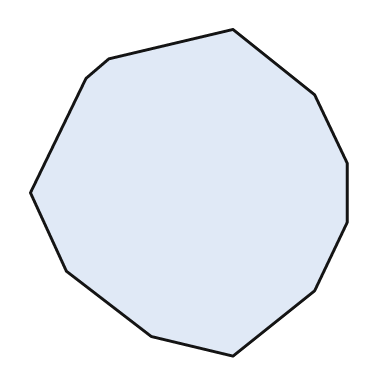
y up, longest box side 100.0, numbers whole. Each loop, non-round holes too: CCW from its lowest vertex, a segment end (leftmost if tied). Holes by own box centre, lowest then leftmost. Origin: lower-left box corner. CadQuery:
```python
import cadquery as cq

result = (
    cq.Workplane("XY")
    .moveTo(62.0, 0.0)
    .lineTo(87.0, 20.0)
    .lineTo(97.0, 41.0)
    .lineTo(97.0, 59.0)
    .lineTo(87.0, 80.0)
    .lineTo(62.0, 100.0)
    .lineTo(24.0, 91.0)
    .lineTo(17.0, 85.0)
    .lineTo(0.0, 50.0)
    .lineTo(11.0, 26.0)
    .lineTo(37.0, 6.0)
    .close()
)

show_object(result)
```